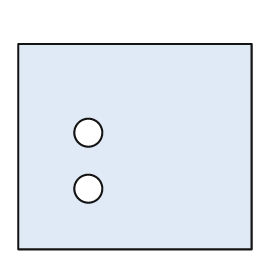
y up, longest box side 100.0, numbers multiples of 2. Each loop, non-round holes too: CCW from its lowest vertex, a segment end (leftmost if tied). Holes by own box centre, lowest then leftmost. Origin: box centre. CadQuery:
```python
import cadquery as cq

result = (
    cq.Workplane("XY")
    .moveTo(-50.0, -44.0)
    .lineTo(50.0, -44.0)
    .lineTo(50.0, 44.0)
    .lineTo(-50.0, 44.0)
    .close()
    .moveTo(-20.0, -18.0)
    .circle(6.0)
    .moveTo(-20.0, 6.0)
    .circle(6.0)
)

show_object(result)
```